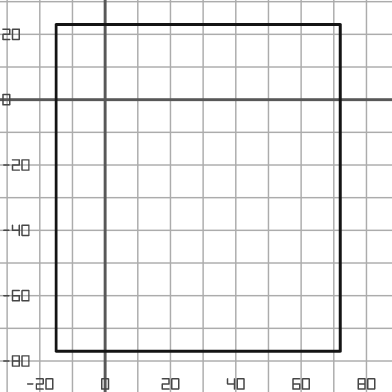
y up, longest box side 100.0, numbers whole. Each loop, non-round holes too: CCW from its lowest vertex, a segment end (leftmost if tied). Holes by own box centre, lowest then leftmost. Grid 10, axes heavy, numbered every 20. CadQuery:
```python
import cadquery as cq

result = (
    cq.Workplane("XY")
    .moveTo(-15.0, -77.0)
    .lineTo(72.0, -77.0)
    .lineTo(72.0, 23.0)
    .lineTo(-15.0, 23.0)
    .close()
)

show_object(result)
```